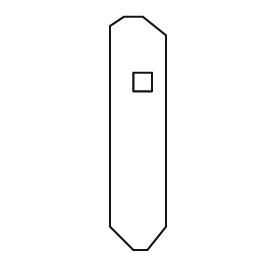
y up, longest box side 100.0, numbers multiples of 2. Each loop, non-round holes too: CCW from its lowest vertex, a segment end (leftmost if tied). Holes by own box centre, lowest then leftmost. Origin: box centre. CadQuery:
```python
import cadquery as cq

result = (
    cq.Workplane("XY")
    .moveTo(-2.0, -50.0)
    .lineTo(4.0, -50.0)
    .lineTo(12.0, -40.0)
    .lineTo(12.0, 42.0)
    .lineTo(2.0, 50.0)
    .lineTo(-6.0, 50.0)
    .lineTo(-12.0, 46.0)
    .lineTo(-12.0, -40.0)
    .close()
    .moveTo(-2.0, 18.0)
    .lineTo(6.0, 18.0)
    .lineTo(6.0, 26.0)
    .lineTo(-2.0, 26.0)
    .close()
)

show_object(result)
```